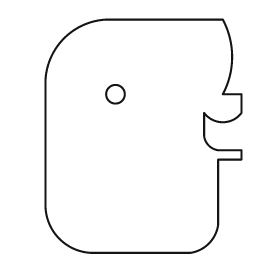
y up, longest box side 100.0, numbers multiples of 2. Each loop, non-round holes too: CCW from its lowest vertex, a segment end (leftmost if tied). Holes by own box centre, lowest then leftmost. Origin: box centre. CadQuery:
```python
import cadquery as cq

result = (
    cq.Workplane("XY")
    .moveTo(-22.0, -50.0)
    .lineTo(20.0, -50.0)
    .threePointArc((28.0, -46.0), (32.0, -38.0))
    .lineTo(32.0, -10.0)
    .lineTo(42.0, -10.0)
    .lineTo(42.0, -6.0)
    .lineTo(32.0, -6.0)
    .threePointArc((28.0, -4.0), (26.0, 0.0))
    .lineTo(26.0, 10.0)
    .threePointArc((34.0, 6.0), (42.0, 10.0))
    .lineTo(42.0, 18.0)
    .lineTo(34.0, 18.0)
    .threePointArc((38.0, 34.0), (34.0, 50.0))
    .lineTo(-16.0, 50.0)
    .threePointArc((-34.0, 42.0), (-42.0, 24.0))
    .lineTo(-42.0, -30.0)
    .threePointArc((-36.0, -44.0), (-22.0, -50.0))
    .close()
    .moveTo(-12.0, 18.0)
    .circle(4.0)
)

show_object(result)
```